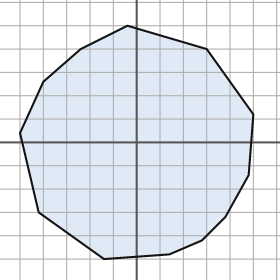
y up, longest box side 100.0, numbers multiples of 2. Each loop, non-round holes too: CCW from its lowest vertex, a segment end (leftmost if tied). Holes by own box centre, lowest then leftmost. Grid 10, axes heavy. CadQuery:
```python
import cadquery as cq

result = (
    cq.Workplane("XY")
    .moveTo(-14.0, -50.0)
    .lineTo(14.0, -48.0)
    .lineTo(28.0, -42.0)
    .lineTo(38.0, -32.0)
    .lineTo(48.0, -14.0)
    .lineTo(50.0, 12.0)
    .lineTo(30.0, 40.0)
    .lineTo(-4.0, 50.0)
    .lineTo(-24.0, 40.0)
    .lineTo(-40.0, 26.0)
    .lineTo(-50.0, 4.0)
    .lineTo(-42.0, -30.0)
    .close()
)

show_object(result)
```